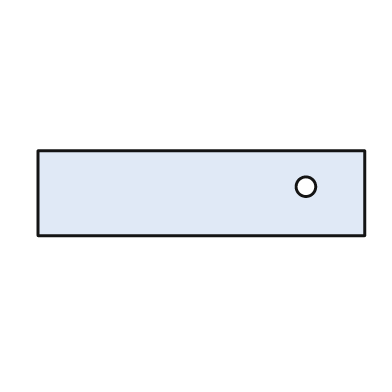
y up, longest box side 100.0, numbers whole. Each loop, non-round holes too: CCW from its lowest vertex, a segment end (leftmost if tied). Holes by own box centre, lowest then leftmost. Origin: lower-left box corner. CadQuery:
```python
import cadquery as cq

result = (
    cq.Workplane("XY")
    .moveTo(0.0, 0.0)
    .lineTo(100.0, 0.0)
    .lineTo(100.0, 26.0)
    .lineTo(0.0, 26.0)
    .close()
    .moveTo(82.0, 15.0)
    .circle(3.0)
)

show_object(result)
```